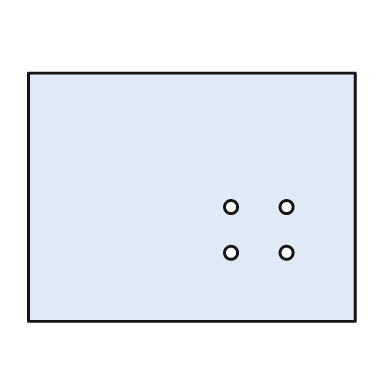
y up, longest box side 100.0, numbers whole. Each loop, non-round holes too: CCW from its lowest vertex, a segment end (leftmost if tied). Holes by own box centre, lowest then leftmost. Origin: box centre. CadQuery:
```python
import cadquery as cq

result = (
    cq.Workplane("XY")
    .moveTo(-50.0, -38.0)
    .lineTo(50.0, -38.0)
    .lineTo(50.0, 38.0)
    .lineTo(-50.0, 38.0)
    .close()
    .moveTo(12.0, -17.0)
    .circle(2.0)
    .moveTo(29.0, -17.0)
    .circle(2.0)
    .moveTo(12.0, -3.0)
    .circle(2.0)
    .moveTo(29.0, -3.0)
    .circle(2.0)
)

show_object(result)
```